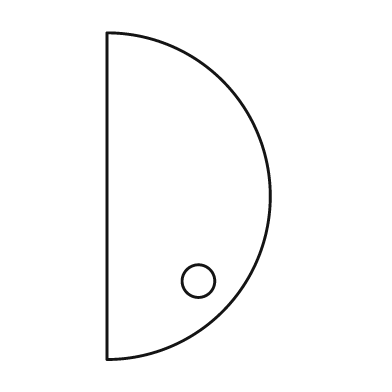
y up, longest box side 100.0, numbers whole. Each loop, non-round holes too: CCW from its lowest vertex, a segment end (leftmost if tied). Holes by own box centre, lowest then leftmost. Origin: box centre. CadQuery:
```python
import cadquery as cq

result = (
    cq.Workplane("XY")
    .moveTo(-25.0, -50.0)
    .threePointArc((25.0, 0.0), (-25.0, 50.0))
    .close()
    .moveTo(3.0, -26.0)
    .circle(5.0)
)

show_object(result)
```